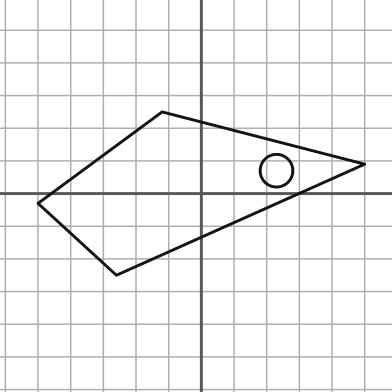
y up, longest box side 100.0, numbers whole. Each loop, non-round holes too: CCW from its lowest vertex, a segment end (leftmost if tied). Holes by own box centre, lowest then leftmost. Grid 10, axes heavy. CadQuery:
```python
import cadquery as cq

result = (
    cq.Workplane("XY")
    .moveTo(-26.0, -25.0)
    .lineTo(50.0, 9.0)
    .lineTo(-12.0, 25.0)
    .lineTo(-50.0, -3.0)
    .close()
    .moveTo(23.0, 7.0)
    .circle(5.0)
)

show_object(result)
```